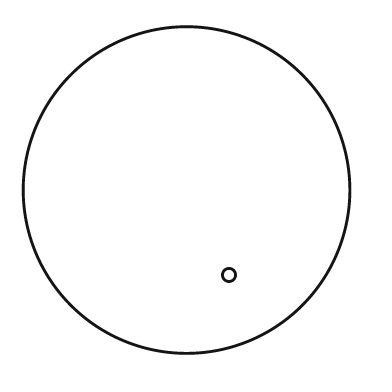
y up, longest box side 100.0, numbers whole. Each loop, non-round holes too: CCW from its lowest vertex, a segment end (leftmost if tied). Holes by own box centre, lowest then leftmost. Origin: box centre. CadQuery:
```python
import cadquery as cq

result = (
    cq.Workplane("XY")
    .moveTo(0.0, 0.0)
    .circle(50.0)
    .moveTo(13.0, -26.0)
    .circle(2.0)
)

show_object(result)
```